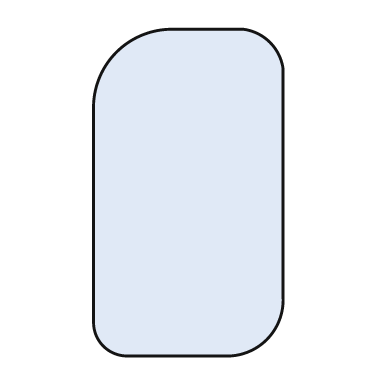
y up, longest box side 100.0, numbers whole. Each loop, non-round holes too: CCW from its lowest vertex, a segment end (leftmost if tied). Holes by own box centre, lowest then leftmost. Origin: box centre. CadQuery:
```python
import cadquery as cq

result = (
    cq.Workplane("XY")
    .moveTo(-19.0, -50.0)
    .lineTo(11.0, -50.0)
    .threePointArc((24.0, -45.0), (29.0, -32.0))
    .lineTo(29.0, 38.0)
    .threePointArc((25.0, 46.0), (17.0, 50.0))
    .lineTo(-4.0, 50.0)
    .threePointArc((-22.0, 43.0), (-29.0, 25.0))
    .lineTo(-29.0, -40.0)
    .threePointArc((-26.0, -47.0), (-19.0, -50.0))
    .close()
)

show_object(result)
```